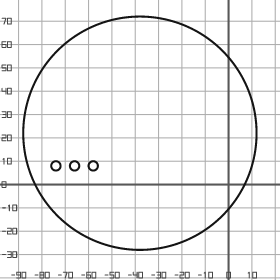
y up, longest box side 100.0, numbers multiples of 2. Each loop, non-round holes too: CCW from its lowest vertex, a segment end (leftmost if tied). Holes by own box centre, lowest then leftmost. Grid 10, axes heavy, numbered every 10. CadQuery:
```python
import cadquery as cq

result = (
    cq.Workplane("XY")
    .moveTo(-38.0, 22.0)
    .circle(50.0)
    .moveTo(-74.0, 8.0)
    .circle(2.0)
    .moveTo(-66.0, 8.0)
    .circle(2.0)
    .moveTo(-58.0, 8.0)
    .circle(2.0)
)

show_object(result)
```